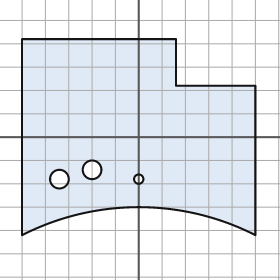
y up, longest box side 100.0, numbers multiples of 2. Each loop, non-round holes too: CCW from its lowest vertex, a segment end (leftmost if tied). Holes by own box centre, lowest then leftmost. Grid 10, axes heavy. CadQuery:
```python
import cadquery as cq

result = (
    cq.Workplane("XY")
    .moveTo(-50.0, -42.0)
    .threePointArc((0.0, -30.0), (50.0, -42.0))
    .lineTo(50.0, 22.0)
    .lineTo(16.0, 22.0)
    .lineTo(16.0, 42.0)
    .lineTo(-50.0, 42.0)
    .close()
    .moveTo(-34.0, -18.0)
    .circle(4.0)
    .moveTo(0.0, -18.0)
    .circle(2.0)
    .moveTo(-20.0, -14.0)
    .circle(4.0)
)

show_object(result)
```